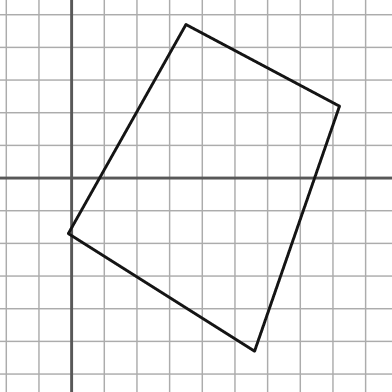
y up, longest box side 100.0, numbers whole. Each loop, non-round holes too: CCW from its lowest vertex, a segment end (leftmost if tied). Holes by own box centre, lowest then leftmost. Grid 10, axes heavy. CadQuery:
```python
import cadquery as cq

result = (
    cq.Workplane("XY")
    .moveTo(56.0, -53.0)
    .lineTo(82.0, 22.0)
    .lineTo(35.0, 47.0)
    .lineTo(-1.0, -17.0)
    .close()
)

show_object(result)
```